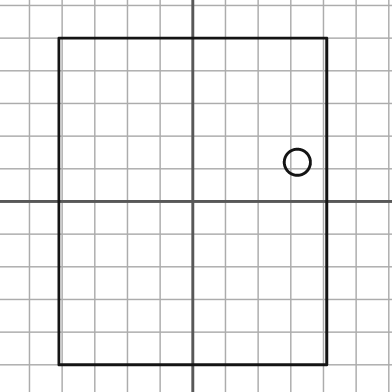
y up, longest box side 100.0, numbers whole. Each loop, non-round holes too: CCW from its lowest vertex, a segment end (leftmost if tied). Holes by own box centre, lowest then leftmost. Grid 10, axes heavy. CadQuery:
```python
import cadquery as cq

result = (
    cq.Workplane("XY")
    .moveTo(-41.0, -50.0)
    .lineTo(41.0, -50.0)
    .lineTo(41.0, 50.0)
    .lineTo(-41.0, 50.0)
    .close()
    .moveTo(32.0, 12.0)
    .circle(4.0)
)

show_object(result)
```